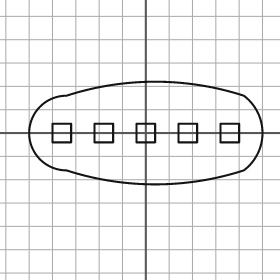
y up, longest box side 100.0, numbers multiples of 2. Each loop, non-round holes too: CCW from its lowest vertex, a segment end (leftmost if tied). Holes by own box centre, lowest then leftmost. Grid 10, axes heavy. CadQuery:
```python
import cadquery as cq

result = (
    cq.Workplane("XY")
    .moveTo(-34.0, -16.0)
    .threePointArc((4.0, -22.0), (42.0, -16.0))
    .threePointArc((50.0, 0.0), (42.0, 16.0))
    .threePointArc((4.0, 22.0), (-34.0, 16.0))
    .threePointArc((-50.0, 0.0), (-34.0, -16.0))
    .close()
    .moveTo(-40.0, -4.0)
    .lineTo(-32.0, -4.0)
    .lineTo(-32.0, 4.0)
    .lineTo(-40.0, 4.0)
    .close()
    .moveTo(-22.0, -4.0)
    .lineTo(-14.0, -4.0)
    .lineTo(-14.0, 4.0)
    .lineTo(-22.0, 4.0)
    .close()
    .moveTo(-4.0, -4.0)
    .lineTo(4.0, -4.0)
    .lineTo(4.0, 4.0)
    .lineTo(-4.0, 4.0)
    .close()
    .moveTo(14.0, -4.0)
    .lineTo(22.0, -4.0)
    .lineTo(22.0, 4.0)
    .lineTo(14.0, 4.0)
    .close()
    .moveTo(32.0, -4.0)
    .lineTo(40.0, -4.0)
    .lineTo(40.0, 4.0)
    .lineTo(32.0, 4.0)
    .close()
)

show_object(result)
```